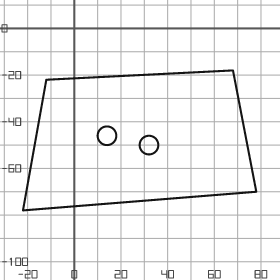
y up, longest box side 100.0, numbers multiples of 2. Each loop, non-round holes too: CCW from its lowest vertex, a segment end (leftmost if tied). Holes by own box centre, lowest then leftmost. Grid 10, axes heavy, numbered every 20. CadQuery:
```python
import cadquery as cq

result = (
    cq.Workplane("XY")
    .moveTo(-22.0, -78.0)
    .lineTo(78.0, -70.0)
    .lineTo(68.0, -18.0)
    .lineTo(-12.0, -22.0)
    .close()
    .moveTo(32.0, -50.0)
    .circle(4.0)
    .moveTo(14.0, -46.0)
    .circle(4.0)
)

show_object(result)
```